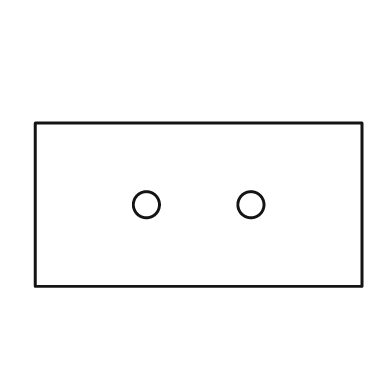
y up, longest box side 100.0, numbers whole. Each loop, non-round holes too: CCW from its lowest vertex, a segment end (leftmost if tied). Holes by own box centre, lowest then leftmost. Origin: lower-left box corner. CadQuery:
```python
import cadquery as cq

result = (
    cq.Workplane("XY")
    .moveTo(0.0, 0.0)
    .lineTo(100.0, 0.0)
    .lineTo(100.0, 50.0)
    .lineTo(0.0, 50.0)
    .close()
    .moveTo(34.0, 25.0)
    .circle(4.0)
    .moveTo(66.0, 25.0)
    .circle(4.0)
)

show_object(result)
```